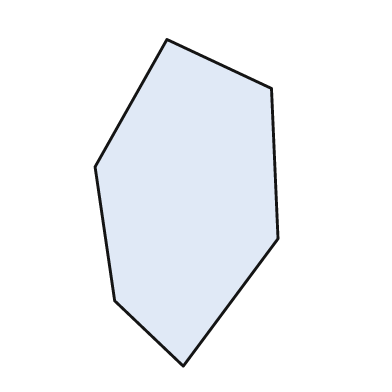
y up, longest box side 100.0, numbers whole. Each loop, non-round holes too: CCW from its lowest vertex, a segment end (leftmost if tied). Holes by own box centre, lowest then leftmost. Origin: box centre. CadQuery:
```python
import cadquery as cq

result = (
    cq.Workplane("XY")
    .moveTo(-1.0, -50.0)
    .lineTo(28.0, -11.0)
    .lineTo(26.0, 35.0)
    .lineTo(-6.0, 50.0)
    .lineTo(-28.0, 11.0)
    .lineTo(-22.0, -30.0)
    .close()
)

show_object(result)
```